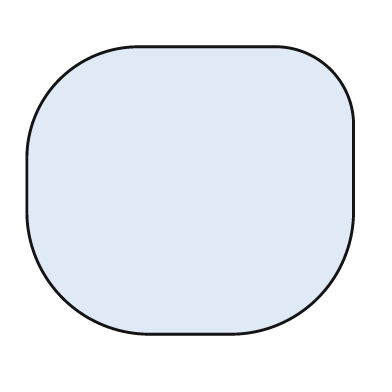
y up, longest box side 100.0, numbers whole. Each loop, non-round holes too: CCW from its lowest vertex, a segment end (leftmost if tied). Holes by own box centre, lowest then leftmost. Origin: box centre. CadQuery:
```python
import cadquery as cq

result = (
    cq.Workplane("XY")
    .moveTo(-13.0, -44.0)
    .lineTo(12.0, -44.0)
    .threePointArc((39.0, -33.0), (50.0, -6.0))
    .lineTo(50.0, 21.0)
    .threePointArc((43.0, 37.0), (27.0, 44.0))
    .lineTo(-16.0, 44.0)
    .threePointArc((-40.0, 34.0), (-50.0, 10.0))
    .lineTo(-50.0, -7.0)
    .threePointArc((-39.0, -33.0), (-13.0, -44.0))
    .close()
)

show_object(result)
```